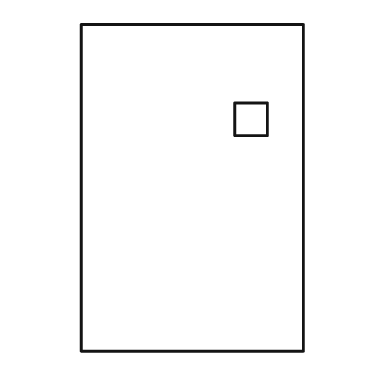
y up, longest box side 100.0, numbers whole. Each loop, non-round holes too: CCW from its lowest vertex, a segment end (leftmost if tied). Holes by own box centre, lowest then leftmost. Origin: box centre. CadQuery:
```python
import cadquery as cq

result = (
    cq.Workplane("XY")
    .moveTo(-34.0, -50.0)
    .lineTo(34.0, -50.0)
    .lineTo(34.0, 50.0)
    .lineTo(-34.0, 50.0)
    .close()
    .moveTo(13.0, 16.0)
    .lineTo(23.0, 16.0)
    .lineTo(23.0, 26.0)
    .lineTo(13.0, 26.0)
    .close()
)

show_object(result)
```